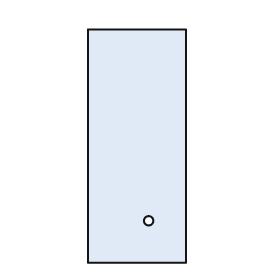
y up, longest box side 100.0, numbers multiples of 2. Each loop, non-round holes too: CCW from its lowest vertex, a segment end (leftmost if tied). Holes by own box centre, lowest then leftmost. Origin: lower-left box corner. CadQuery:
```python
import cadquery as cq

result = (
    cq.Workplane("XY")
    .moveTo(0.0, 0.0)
    .lineTo(42.0, 0.0)
    .lineTo(42.0, 100.0)
    .lineTo(0.0, 100.0)
    .close()
    .moveTo(26.0, 18.0)
    .circle(2.0)
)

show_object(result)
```